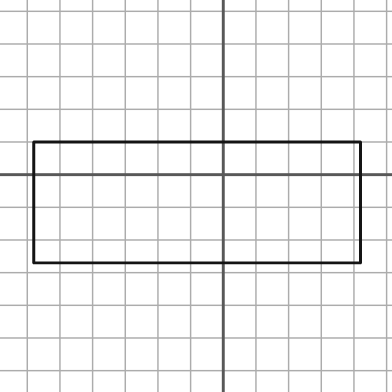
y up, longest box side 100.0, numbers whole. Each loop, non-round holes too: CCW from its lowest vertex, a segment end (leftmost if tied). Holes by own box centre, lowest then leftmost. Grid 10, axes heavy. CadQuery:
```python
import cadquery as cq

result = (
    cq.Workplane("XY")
    .moveTo(-58.0, -27.0)
    .lineTo(42.0, -27.0)
    .lineTo(42.0, 10.0)
    .lineTo(-58.0, 10.0)
    .close()
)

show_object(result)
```